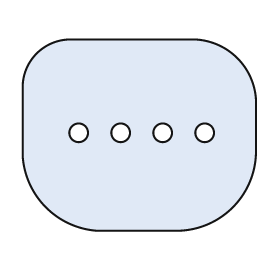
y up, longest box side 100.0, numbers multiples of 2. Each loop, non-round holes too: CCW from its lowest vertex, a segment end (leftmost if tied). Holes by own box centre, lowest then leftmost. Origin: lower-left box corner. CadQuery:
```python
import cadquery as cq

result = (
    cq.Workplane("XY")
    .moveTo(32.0, 0.0)
    .lineTo(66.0, 0.0)
    .threePointArc((90.0, 10.0), (100.0, 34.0))
    .lineTo(100.0, 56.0)
    .threePointArc((92.0, 74.0), (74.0, 82.0))
    .lineTo(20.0, 82.0)
    .threePointArc((6.0, 76.0), (0.0, 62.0))
    .lineTo(0.0, 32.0)
    .threePointArc((10.0, 10.0), (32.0, 0.0))
    .close()
    .moveTo(24.0, 42.0)
    .circle(4.0)
    .moveTo(42.0, 42.0)
    .circle(4.0)
    .moveTo(60.0, 42.0)
    .circle(4.0)
    .moveTo(78.0, 42.0)
    .circle(4.0)
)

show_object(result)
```